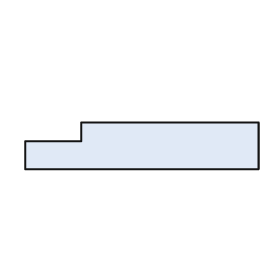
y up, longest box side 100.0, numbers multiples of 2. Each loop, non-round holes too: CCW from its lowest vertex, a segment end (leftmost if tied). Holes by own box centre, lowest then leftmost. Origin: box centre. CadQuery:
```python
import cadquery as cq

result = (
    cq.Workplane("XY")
    .moveTo(-50.0, -10.0)
    .lineTo(50.0, -10.0)
    .lineTo(50.0, 10.0)
    .lineTo(-26.0, 10.0)
    .lineTo(-26.0, 2.0)
    .lineTo(-50.0, 2.0)
    .close()
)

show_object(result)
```